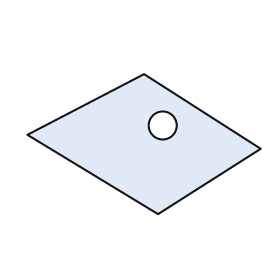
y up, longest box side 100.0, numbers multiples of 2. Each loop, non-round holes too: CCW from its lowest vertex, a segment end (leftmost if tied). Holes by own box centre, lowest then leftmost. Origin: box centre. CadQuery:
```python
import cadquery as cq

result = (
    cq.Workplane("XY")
    .moveTo(6.0, -30.0)
    .lineTo(50.0, -2.0)
    .lineTo(0.0, 30.0)
    .lineTo(-50.0, 4.0)
    .close()
    .moveTo(8.0, 8.0)
    .circle(6.0)
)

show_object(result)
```